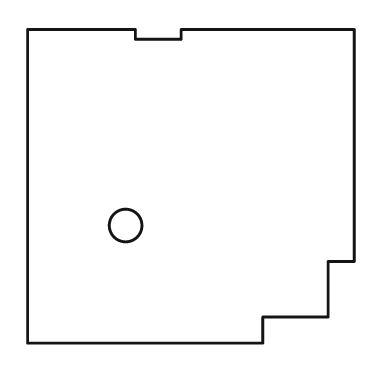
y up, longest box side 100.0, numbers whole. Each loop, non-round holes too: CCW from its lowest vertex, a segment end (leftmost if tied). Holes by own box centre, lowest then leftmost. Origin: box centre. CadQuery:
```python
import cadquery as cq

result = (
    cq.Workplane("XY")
    .moveTo(-50.0, -48.0)
    .lineTo(22.0, -48.0)
    .lineTo(22.0, -40.0)
    .lineTo(42.0, -40.0)
    .lineTo(42.0, -23.0)
    .lineTo(50.0, -23.0)
    .lineTo(50.0, 48.0)
    .lineTo(-3.0, 48.0)
    .lineTo(-3.0, 45.0)
    .lineTo(-17.0, 45.0)
    .lineTo(-17.0, 48.0)
    .lineTo(-50.0, 48.0)
    .close()
    .moveTo(-20.0, -12.0)
    .circle(5.0)
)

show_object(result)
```